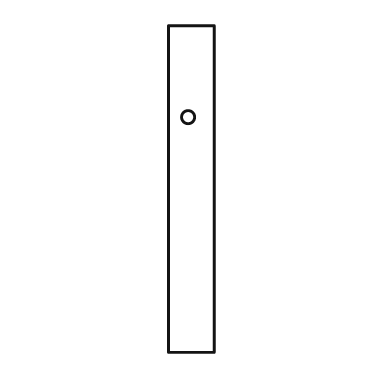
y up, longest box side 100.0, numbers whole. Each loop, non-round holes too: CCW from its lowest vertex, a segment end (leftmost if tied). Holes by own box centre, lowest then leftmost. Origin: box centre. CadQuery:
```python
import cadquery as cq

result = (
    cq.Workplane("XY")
    .moveTo(-7.0, -50.0)
    .lineTo(7.0, -50.0)
    .lineTo(7.0, 50.0)
    .lineTo(-7.0, 50.0)
    .close()
    .moveTo(-1.0, 22.0)
    .circle(2.0)
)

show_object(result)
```